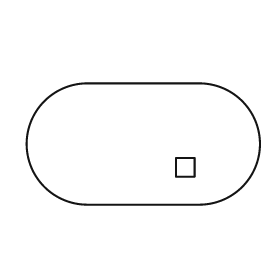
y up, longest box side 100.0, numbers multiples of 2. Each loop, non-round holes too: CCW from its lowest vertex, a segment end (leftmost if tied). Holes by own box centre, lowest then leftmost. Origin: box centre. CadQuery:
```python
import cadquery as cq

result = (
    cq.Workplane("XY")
    .moveTo(-24.0, -26.0)
    .lineTo(24.0, -26.0)
    .threePointArc((50.0, 0.0), (24.0, 26.0))
    .lineTo(-24.0, 26.0)
    .threePointArc((-50.0, 0.0), (-24.0, -26.0))
    .close()
    .moveTo(14.0, -14.0)
    .lineTo(22.0, -14.0)
    .lineTo(22.0, -6.0)
    .lineTo(14.0, -6.0)
    .close()
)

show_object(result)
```